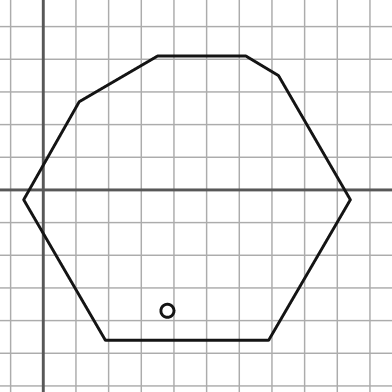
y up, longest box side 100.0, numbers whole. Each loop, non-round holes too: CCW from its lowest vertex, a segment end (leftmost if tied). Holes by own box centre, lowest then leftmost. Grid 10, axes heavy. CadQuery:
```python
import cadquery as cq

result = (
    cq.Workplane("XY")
    .moveTo(19.0, -46.0)
    .lineTo(69.0, -46.0)
    .lineTo(94.0, -3.0)
    .lineTo(72.0, 35.0)
    .lineTo(62.0, 41.0)
    .lineTo(35.0, 41.0)
    .lineTo(11.0, 27.0)
    .lineTo(-6.0, -3.0)
    .close()
    .moveTo(38.0, -37.0)
    .circle(2.0)
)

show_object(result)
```